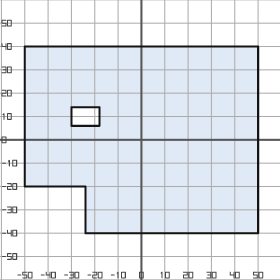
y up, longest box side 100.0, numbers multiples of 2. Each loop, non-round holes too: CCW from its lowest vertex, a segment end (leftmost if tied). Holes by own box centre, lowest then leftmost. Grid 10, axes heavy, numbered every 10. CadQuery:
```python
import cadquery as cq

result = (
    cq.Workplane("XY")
    .moveTo(-24.0, -40.0)
    .lineTo(50.0, -40.0)
    .lineTo(50.0, 40.0)
    .lineTo(-50.0, 40.0)
    .lineTo(-50.0, -20.0)
    .lineTo(-24.0, -20.0)
    .close()
    .moveTo(-30.0, 6.0)
    .lineTo(-18.0, 6.0)
    .lineTo(-18.0, 14.0)
    .lineTo(-30.0, 14.0)
    .close()
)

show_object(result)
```